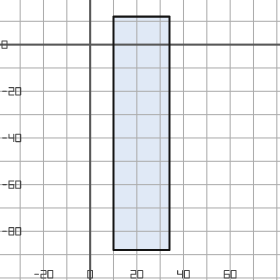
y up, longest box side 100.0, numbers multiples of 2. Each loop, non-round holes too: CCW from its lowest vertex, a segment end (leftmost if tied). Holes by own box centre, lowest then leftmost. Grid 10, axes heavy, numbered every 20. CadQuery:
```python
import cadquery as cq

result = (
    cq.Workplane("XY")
    .moveTo(10.0, -88.0)
    .lineTo(34.0, -88.0)
    .lineTo(34.0, 12.0)
    .lineTo(10.0, 12.0)
    .close()
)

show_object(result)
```